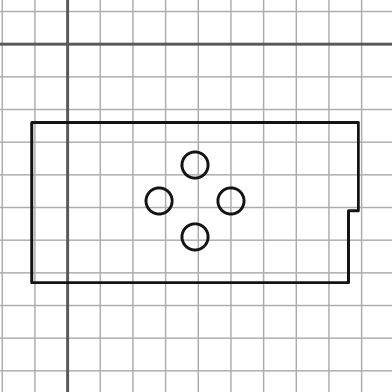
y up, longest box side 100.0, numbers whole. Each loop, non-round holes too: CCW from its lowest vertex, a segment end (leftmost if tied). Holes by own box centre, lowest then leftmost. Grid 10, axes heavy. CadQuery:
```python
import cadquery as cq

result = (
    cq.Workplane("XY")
    .moveTo(-11.0, -73.0)
    .lineTo(86.0, -73.0)
    .lineTo(86.0, -51.0)
    .lineTo(89.0, -51.0)
    .lineTo(89.0, -24.0)
    .lineTo(-11.0, -24.0)
    .close()
    .moveTo(39.0, -59.0)
    .circle(4.0)
    .moveTo(28.0, -48.0)
    .circle(4.0)
    .moveTo(50.0, -48.0)
    .circle(4.0)
    .moveTo(39.0, -37.0)
    .circle(4.0)
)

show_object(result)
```